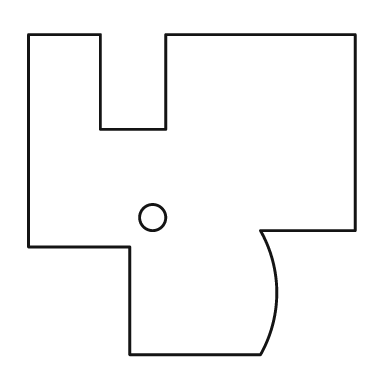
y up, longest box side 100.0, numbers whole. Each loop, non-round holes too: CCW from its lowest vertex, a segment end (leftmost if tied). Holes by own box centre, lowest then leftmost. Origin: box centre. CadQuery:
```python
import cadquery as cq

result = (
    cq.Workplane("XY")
    .moveTo(-19.0, -49.0)
    .lineTo(21.0, -49.0)
    .threePointArc((26.0, -30.0), (21.0, -11.0))
    .lineTo(50.0, -11.0)
    .lineTo(50.0, 49.0)
    .lineTo(-8.0, 49.0)
    .lineTo(-8.0, 20.0)
    .lineTo(-28.0, 20.0)
    .lineTo(-28.0, 49.0)
    .lineTo(-50.0, 49.0)
    .lineTo(-50.0, -16.0)
    .lineTo(-19.0, -16.0)
    .close()
    .moveTo(-12.0, -7.0)
    .circle(4.0)
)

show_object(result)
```